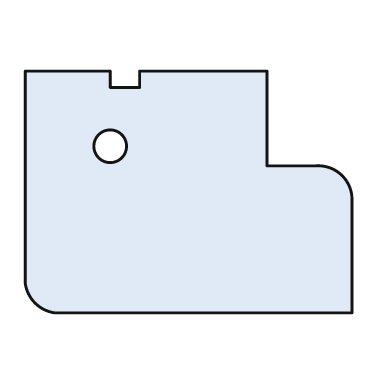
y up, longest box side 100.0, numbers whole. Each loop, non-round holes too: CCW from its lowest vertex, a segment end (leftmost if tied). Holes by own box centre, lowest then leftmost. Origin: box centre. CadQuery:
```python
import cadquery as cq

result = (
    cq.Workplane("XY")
    .moveTo(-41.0, -37.0)
    .lineTo(50.0, -37.0)
    .lineTo(50.0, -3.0)
    .threePointArc((47.0, 5.0), (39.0, 8.0))
    .lineTo(24.0, 8.0)
    .lineTo(24.0, 37.0)
    .lineTo(-15.0, 37.0)
    .lineTo(-15.0, 32.0)
    .lineTo(-24.0, 32.0)
    .lineTo(-24.0, 37.0)
    .lineTo(-50.0, 37.0)
    .lineTo(-50.0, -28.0)
    .threePointArc((-47.0, -34.0), (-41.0, -37.0))
    .close()
    .moveTo(-24.0, 14.0)
    .circle(5.0)
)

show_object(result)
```